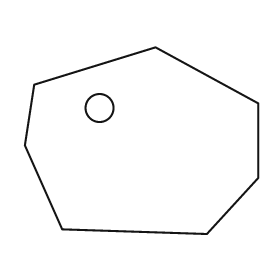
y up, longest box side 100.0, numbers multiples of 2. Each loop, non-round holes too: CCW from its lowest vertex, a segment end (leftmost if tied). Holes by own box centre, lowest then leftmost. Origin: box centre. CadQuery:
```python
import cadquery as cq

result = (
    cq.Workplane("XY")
    .moveTo(28.0, -40.0)
    .lineTo(50.0, -16.0)
    .lineTo(50.0, 16.0)
    .lineTo(6.0, 40.0)
    .lineTo(-46.0, 24.0)
    .lineTo(-50.0, -2.0)
    .lineTo(-34.0, -38.0)
    .close()
    .moveTo(-18.0, 14.0)
    .circle(6.0)
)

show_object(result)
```